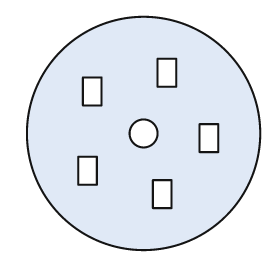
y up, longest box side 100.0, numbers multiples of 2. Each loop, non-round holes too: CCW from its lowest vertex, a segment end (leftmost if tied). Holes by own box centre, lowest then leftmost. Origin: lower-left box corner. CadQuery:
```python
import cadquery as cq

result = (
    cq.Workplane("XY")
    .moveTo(50.0, 50.0)
    .circle(50.0)
    .moveTo(54.0, 18.0)
    .lineTo(62.0, 18.0)
    .lineTo(62.0, 30.0)
    .lineTo(54.0, 30.0)
    .close()
    .moveTo(22.0, 28.0)
    .lineTo(30.0, 28.0)
    .lineTo(30.0, 40.0)
    .lineTo(22.0, 40.0)
    .close()
    .moveTo(74.0, 42.0)
    .lineTo(82.0, 42.0)
    .lineTo(82.0, 54.0)
    .lineTo(74.0, 54.0)
    .close()
    .moveTo(50.0, 50.0)
    .circle(6.0)
    .moveTo(24.0, 62.0)
    .lineTo(32.0, 62.0)
    .lineTo(32.0, 74.0)
    .lineTo(24.0, 74.0)
    .close()
    .moveTo(56.0, 70.0)
    .lineTo(64.0, 70.0)
    .lineTo(64.0, 82.0)
    .lineTo(56.0, 82.0)
    .close()
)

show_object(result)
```